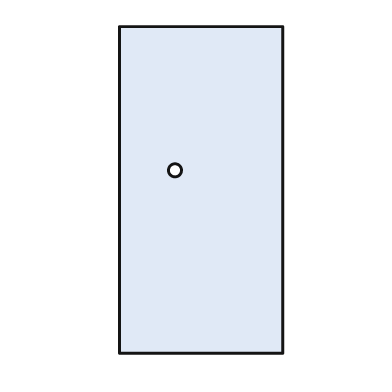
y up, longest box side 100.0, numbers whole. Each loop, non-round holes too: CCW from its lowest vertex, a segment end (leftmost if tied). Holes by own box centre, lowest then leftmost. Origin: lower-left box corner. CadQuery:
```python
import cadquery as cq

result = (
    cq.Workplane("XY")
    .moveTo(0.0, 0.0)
    .lineTo(50.0, 0.0)
    .lineTo(50.0, 100.0)
    .lineTo(0.0, 100.0)
    .close()
    .moveTo(17.0, 56.0)
    .circle(2.0)
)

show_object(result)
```